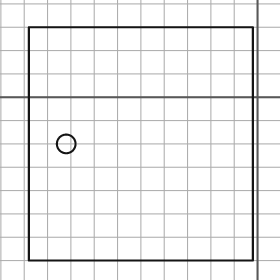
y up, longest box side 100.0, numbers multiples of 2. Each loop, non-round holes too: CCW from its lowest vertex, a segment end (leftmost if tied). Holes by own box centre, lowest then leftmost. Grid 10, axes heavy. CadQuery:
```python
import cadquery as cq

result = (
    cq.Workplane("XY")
    .moveTo(-98.0, -70.0)
    .lineTo(-2.0, -70.0)
    .lineTo(-2.0, 30.0)
    .lineTo(-98.0, 30.0)
    .close()
    .moveTo(-82.0, -20.0)
    .circle(4.0)
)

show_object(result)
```